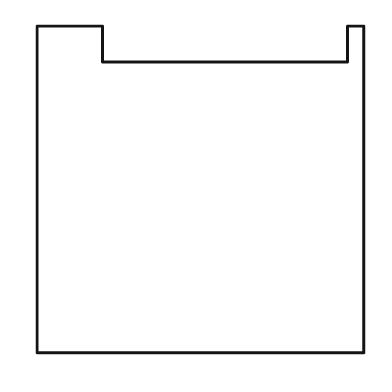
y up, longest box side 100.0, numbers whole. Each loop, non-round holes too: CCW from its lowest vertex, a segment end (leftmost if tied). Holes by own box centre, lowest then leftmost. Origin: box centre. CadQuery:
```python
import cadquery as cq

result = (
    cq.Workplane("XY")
    .moveTo(-50.0, -50.0)
    .lineTo(50.0, -50.0)
    .lineTo(50.0, 50.0)
    .lineTo(45.0, 50.0)
    .lineTo(45.0, 39.0)
    .lineTo(-30.0, 39.0)
    .lineTo(-30.0, 50.0)
    .lineTo(-50.0, 50.0)
    .close()
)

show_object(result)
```